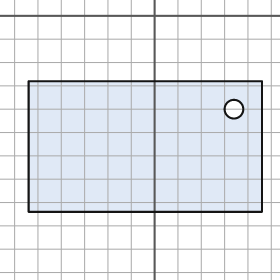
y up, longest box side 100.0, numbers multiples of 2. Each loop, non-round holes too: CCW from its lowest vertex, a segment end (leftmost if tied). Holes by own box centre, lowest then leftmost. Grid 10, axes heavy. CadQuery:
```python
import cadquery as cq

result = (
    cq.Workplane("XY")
    .moveTo(-54.0, -84.0)
    .lineTo(46.0, -84.0)
    .lineTo(46.0, -28.0)
    .lineTo(-54.0, -28.0)
    .close()
    .moveTo(34.0, -40.0)
    .circle(4.0)
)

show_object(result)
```